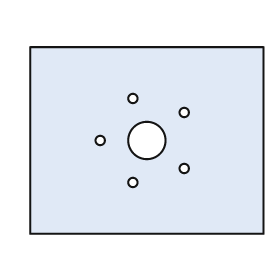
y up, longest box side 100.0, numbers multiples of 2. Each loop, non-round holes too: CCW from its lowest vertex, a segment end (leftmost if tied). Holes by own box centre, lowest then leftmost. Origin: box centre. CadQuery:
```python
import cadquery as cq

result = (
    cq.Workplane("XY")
    .moveTo(-50.0, -40.0)
    .lineTo(50.0, -40.0)
    .lineTo(50.0, 40.0)
    .lineTo(-50.0, 40.0)
    .close()
    .moveTo(-6.0, -18.0)
    .circle(2.0)
    .moveTo(16.0, -12.0)
    .circle(2.0)
    .moveTo(-20.0, 0.0)
    .circle(2.0)
    .moveTo(0.0, 0.0)
    .circle(8.0)
    .moveTo(16.0, 12.0)
    .circle(2.0)
    .moveTo(-6.0, 18.0)
    .circle(2.0)
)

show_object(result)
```